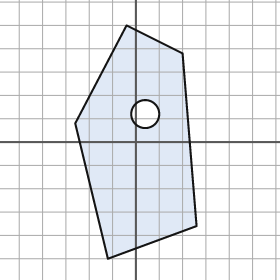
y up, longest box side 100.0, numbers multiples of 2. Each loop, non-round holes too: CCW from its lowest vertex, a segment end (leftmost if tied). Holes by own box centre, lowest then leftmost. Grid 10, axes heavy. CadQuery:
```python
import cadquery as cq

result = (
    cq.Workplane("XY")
    .moveTo(-12.0, -50.0)
    .lineTo(26.0, -36.0)
    .lineTo(20.0, 38.0)
    .lineTo(-4.0, 50.0)
    .lineTo(-26.0, 8.0)
    .close()
    .moveTo(4.0, 12.0)
    .circle(6.0)
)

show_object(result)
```